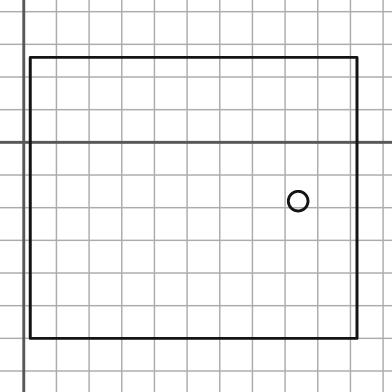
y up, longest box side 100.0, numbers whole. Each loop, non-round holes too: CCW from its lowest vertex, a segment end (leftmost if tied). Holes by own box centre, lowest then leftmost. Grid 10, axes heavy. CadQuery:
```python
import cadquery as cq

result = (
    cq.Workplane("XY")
    .moveTo(2.0, -60.0)
    .lineTo(102.0, -60.0)
    .lineTo(102.0, 26.0)
    .lineTo(2.0, 26.0)
    .close()
    .moveTo(84.0, -18.0)
    .circle(3.0)
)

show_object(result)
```